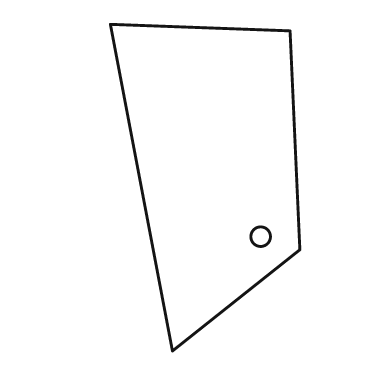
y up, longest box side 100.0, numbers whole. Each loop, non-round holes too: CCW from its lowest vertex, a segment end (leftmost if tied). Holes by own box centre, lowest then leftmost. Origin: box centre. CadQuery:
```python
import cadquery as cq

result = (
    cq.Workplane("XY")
    .moveTo(-10.0, -50.0)
    .lineTo(29.0, -19.0)
    .lineTo(26.0, 48.0)
    .lineTo(-29.0, 50.0)
    .close()
    .moveTo(17.0, -15.0)
    .circle(3.0)
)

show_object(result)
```